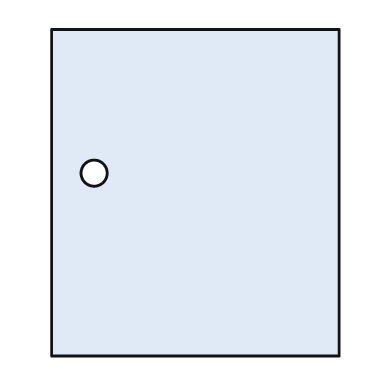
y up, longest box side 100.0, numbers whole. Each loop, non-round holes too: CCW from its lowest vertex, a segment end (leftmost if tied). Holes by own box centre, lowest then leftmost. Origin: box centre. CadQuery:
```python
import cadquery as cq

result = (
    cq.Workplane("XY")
    .moveTo(-44.0, -50.0)
    .lineTo(44.0, -50.0)
    .lineTo(44.0, 50.0)
    .lineTo(-44.0, 50.0)
    .close()
    .moveTo(-31.0, 6.0)
    .circle(4.0)
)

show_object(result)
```